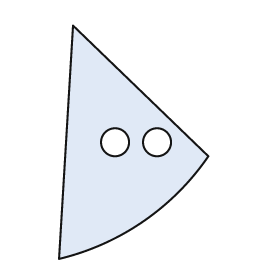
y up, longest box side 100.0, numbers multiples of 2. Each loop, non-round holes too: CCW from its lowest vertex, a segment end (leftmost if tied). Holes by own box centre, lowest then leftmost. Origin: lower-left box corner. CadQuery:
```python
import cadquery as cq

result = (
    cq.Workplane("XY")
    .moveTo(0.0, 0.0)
    .threePointArc((36.0, 16.0), (64.0, 44.0))
    .lineTo(6.0, 100.0)
    .close()
    .moveTo(24.0, 50.0)
    .circle(6.0)
    .moveTo(42.0, 50.0)
    .circle(6.0)
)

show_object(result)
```